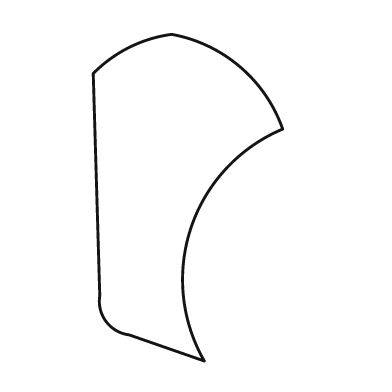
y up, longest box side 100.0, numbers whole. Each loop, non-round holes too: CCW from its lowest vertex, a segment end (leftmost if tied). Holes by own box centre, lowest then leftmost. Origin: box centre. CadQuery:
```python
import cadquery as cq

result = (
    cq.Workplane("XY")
    .moveTo(5.0, -50.0)
    .threePointArc((1.0, -9.0), (29.0, 21.0))
    .threePointArc((16.0, 40.0), (-5.0, 50.0))
    .threePointArc((-18.0, 46.0), (-29.0, 38.0))
    .lineTo(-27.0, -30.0)
    .threePointArc((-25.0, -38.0), (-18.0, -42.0))
    .close()
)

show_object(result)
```